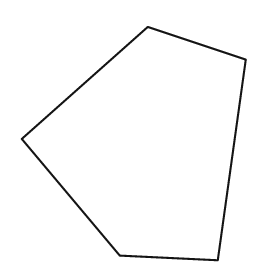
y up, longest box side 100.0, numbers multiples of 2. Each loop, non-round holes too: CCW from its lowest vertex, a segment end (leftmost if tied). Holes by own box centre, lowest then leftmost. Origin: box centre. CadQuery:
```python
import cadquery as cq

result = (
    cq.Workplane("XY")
    .moveTo(36.0, -50.0)
    .lineTo(48.0, 36.0)
    .lineTo(6.0, 50.0)
    .lineTo(-48.0, 2.0)
    .lineTo(-6.0, -48.0)
    .close()
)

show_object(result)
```